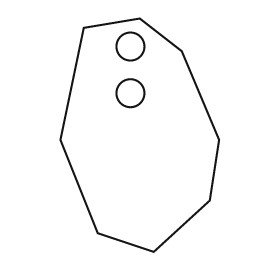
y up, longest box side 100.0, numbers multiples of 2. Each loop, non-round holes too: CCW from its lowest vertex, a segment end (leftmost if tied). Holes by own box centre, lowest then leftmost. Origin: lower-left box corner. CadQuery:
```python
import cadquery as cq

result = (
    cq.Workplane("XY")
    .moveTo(40.0, 0.0)
    .lineTo(64.0, 22.0)
    .lineTo(68.0, 48.0)
    .lineTo(52.0, 86.0)
    .lineTo(34.0, 100.0)
    .lineTo(10.0, 96.0)
    .lineTo(0.0, 48.0)
    .lineTo(16.0, 8.0)
    .close()
    .moveTo(30.0, 68.0)
    .circle(6.0)
    .moveTo(30.0, 88.0)
    .circle(6.0)
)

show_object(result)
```